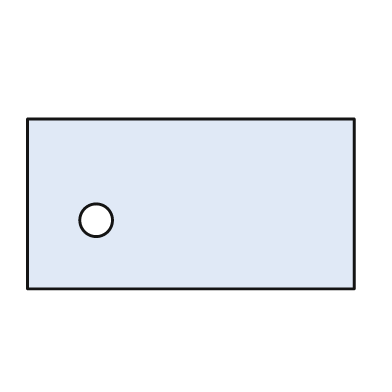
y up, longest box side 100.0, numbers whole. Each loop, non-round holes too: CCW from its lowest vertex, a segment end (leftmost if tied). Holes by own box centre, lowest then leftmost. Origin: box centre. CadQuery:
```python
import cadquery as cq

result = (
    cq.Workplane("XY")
    .moveTo(-50.0, -26.0)
    .lineTo(50.0, -26.0)
    .lineTo(50.0, 26.0)
    .lineTo(-50.0, 26.0)
    .close()
    .moveTo(-29.0, -5.0)
    .circle(5.0)
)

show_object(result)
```